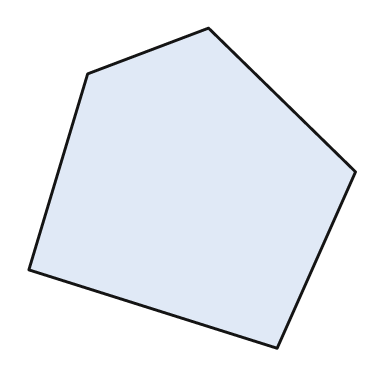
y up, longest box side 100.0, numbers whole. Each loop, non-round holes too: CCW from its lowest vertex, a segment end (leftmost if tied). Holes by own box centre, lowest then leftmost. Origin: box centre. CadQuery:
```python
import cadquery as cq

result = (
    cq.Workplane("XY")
    .moveTo(26.0, -49.0)
    .lineTo(50.0, 5.0)
    .lineTo(5.0, 49.0)
    .lineTo(-32.0, 35.0)
    .lineTo(-50.0, -25.0)
    .close()
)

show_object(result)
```